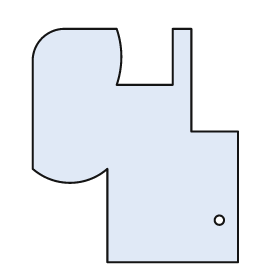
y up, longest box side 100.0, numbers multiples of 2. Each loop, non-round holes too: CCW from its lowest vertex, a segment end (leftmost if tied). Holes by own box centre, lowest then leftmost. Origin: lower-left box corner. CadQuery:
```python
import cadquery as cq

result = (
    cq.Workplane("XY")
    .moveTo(32.0, 0.0)
    .lineTo(88.0, 0.0)
    .lineTo(88.0, 56.0)
    .lineTo(68.0, 56.0)
    .lineTo(68.0, 100.0)
    .lineTo(60.0, 100.0)
    .lineTo(60.0, 76.0)
    .lineTo(36.0, 76.0)
    .threePointArc((38.0, 88.0), (36.0, 100.0))
    .lineTo(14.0, 100.0)
    .threePointArc((4.0, 96.0), (0.0, 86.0))
    .lineTo(0.0, 40.0)
    .threePointArc((16.0, 34.0), (32.0, 40.0))
    .close()
    .moveTo(80.0, 18.0)
    .circle(2.0)
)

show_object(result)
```